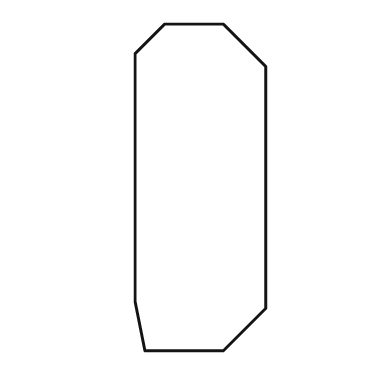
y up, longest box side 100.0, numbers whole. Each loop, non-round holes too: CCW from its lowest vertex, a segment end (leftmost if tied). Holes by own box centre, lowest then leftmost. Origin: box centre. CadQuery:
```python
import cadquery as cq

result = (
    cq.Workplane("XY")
    .moveTo(-17.0, -50.0)
    .lineTo(7.0, -50.0)
    .lineTo(20.0, -37.0)
    .lineTo(20.0, 37.0)
    .lineTo(7.0, 50.0)
    .lineTo(-11.0, 50.0)
    .lineTo(-20.0, 41.0)
    .lineTo(-20.0, -35.0)
    .close()
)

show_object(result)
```